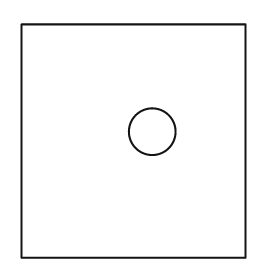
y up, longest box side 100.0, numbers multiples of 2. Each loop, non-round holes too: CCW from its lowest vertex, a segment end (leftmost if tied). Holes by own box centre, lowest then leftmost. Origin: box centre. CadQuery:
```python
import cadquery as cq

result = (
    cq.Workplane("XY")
    .moveTo(-48.0, -50.0)
    .lineTo(48.0, -50.0)
    .lineTo(48.0, 50.0)
    .lineTo(-48.0, 50.0)
    .close()
    .moveTo(8.0, 4.0)
    .circle(10.0)
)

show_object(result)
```